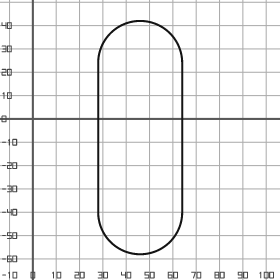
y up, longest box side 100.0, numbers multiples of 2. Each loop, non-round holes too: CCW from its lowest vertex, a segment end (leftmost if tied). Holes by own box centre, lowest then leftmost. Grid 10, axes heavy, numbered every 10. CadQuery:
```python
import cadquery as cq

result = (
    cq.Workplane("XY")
    .moveTo(28.0, -40.0)
    .threePointArc((46.0, -58.0), (64.0, -40.0))
    .lineTo(64.0, 24.0)
    .threePointArc((46.0, 42.0), (28.0, 24.0))
    .close()
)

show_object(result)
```